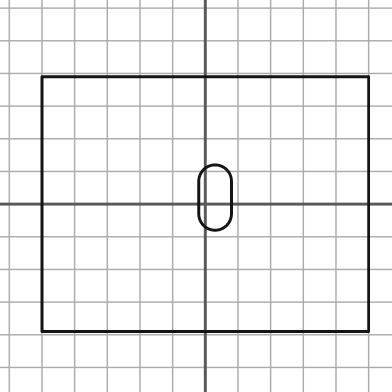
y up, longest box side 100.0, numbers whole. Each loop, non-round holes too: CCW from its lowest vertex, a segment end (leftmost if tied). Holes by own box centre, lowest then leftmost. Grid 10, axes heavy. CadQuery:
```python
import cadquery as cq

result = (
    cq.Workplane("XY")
    .moveTo(-50.0, -39.0)
    .lineTo(50.0, -39.0)
    .lineTo(50.0, 39.0)
    .lineTo(-50.0, 39.0)
    .close()
    .moveTo(-2.0, -3.0)
    .threePointArc((3.0, -8.0), (8.0, -3.0))
    .lineTo(8.0, 7.0)
    .threePointArc((3.0, 12.0), (-2.0, 7.0))
    .close()
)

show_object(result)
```